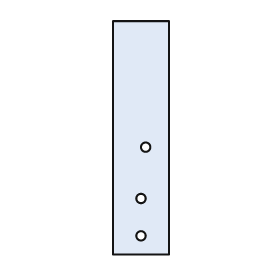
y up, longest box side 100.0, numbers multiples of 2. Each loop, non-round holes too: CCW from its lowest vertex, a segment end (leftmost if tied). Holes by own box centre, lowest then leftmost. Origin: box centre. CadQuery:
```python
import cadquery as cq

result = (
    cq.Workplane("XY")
    .moveTo(-12.0, -50.0)
    .lineTo(12.0, -50.0)
    .lineTo(12.0, 50.0)
    .lineTo(-12.0, 50.0)
    .close()
    .moveTo(0.0, -42.0)
    .circle(2.0)
    .moveTo(0.0, -26.0)
    .circle(2.0)
    .moveTo(2.0, -4.0)
    .circle(2.0)
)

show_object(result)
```